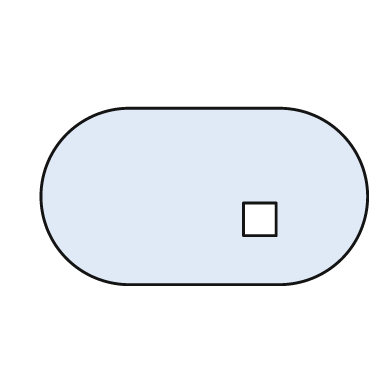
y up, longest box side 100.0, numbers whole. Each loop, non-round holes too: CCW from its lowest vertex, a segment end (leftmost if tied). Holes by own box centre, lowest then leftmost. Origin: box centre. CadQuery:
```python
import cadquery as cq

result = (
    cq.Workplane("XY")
    .moveTo(-23.0, -27.0)
    .lineTo(23.0, -27.0)
    .threePointArc((50.0, 0.0), (23.0, 27.0))
    .lineTo(-23.0, 27.0)
    .threePointArc((-50.0, 0.0), (-23.0, -27.0))
    .close()
    .moveTo(12.0, -12.0)
    .lineTo(22.0, -12.0)
    .lineTo(22.0, -2.0)
    .lineTo(12.0, -2.0)
    .close()
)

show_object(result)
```